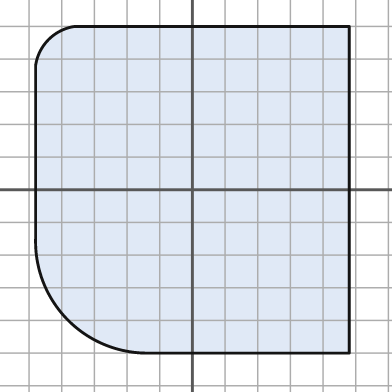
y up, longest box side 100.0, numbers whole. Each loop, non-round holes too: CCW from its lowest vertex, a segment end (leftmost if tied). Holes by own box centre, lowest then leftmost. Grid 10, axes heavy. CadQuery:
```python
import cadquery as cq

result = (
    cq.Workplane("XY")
    .moveTo(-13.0, -50.0)
    .lineTo(48.0, -50.0)
    .lineTo(48.0, 50.0)
    .lineTo(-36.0, 50.0)
    .threePointArc((-44.0, 46.0), (-48.0, 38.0))
    .lineTo(-48.0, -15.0)
    .threePointArc((-38.0, -40.0), (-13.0, -50.0))
    .close()
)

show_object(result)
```